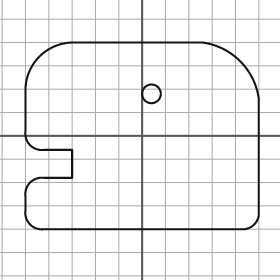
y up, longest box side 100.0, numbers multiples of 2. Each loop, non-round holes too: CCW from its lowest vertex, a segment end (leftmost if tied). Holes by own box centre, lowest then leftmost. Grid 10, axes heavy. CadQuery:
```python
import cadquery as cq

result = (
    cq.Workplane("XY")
    .moveTo(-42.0, -40.0)
    .lineTo(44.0, -40.0)
    .threePointArc((48.0, -38.0), (50.0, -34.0))
    .lineTo(50.0, 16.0)
    .threePointArc((42.0, 32.0), (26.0, 40.0))
    .lineTo(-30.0, 40.0)
    .threePointArc((-44.0, 34.0), (-50.0, 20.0))
    .lineTo(-50.0, 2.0)
    .threePointArc((-48.0, -4.0), (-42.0, -6.0))
    .lineTo(-30.0, -6.0)
    .lineTo(-30.0, -18.0)
    .lineTo(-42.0, -18.0)
    .threePointArc((-48.0, -20.0), (-50.0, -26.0))
    .lineTo(-50.0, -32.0)
    .threePointArc((-48.0, -38.0), (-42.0, -40.0))
    .close()
    .moveTo(4.0, 18.0)
    .circle(4.0)
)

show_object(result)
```